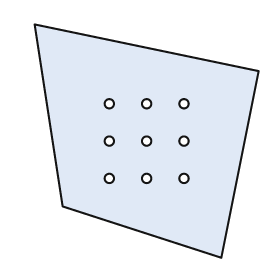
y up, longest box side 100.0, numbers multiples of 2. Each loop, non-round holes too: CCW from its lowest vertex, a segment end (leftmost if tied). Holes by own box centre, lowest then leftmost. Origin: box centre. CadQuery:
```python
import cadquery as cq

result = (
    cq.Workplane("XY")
    .moveTo(32.0, -50.0)
    .lineTo(48.0, 30.0)
    .lineTo(-48.0, 50.0)
    .lineTo(-36.0, -28.0)
    .close()
    .moveTo(-16.0, -16.0)
    .circle(2.0)
    .moveTo(0.0, -16.0)
    .circle(2.0)
    .moveTo(16.0, -16.0)
    .circle(2.0)
    .moveTo(-16.0, 0.0)
    .circle(2.0)
    .moveTo(0.0, 0.0)
    .circle(2.0)
    .moveTo(16.0, 0.0)
    .circle(2.0)
    .moveTo(-16.0, 16.0)
    .circle(2.0)
    .moveTo(0.0, 16.0)
    .circle(2.0)
    .moveTo(16.0, 16.0)
    .circle(2.0)
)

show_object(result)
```